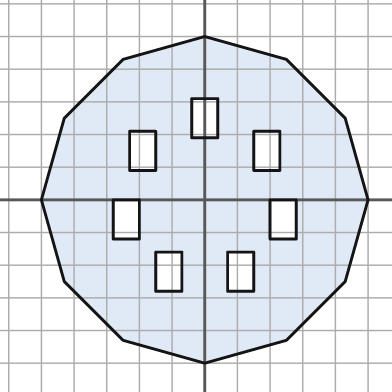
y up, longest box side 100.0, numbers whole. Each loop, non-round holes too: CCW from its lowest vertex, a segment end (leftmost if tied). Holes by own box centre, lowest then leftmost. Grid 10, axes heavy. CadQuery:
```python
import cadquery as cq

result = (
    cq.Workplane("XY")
    .moveTo(0.0, -50.0)
    .lineTo(25.0, -43.0)
    .lineTo(43.0, -25.0)
    .lineTo(50.0, 0.0)
    .lineTo(43.0, 25.0)
    .lineTo(25.0, 43.0)
    .lineTo(0.0, 50.0)
    .lineTo(-25.0, 43.0)
    .lineTo(-43.0, 25.0)
    .lineTo(-50.0, 0.0)
    .lineTo(-43.0, -25.0)
    .lineTo(-25.0, -43.0)
    .close()
    .moveTo(-15.0, -28.0)
    .lineTo(-7.0, -28.0)
    .lineTo(-7.0, -16.0)
    .lineTo(-15.0, -16.0)
    .close()
    .moveTo(7.0, -28.0)
    .lineTo(15.0, -28.0)
    .lineTo(15.0, -16.0)
    .lineTo(7.0, -16.0)
    .close()
    .moveTo(-28.0, -12.0)
    .lineTo(-20.0, -12.0)
    .lineTo(-20.0, 0.0)
    .lineTo(-28.0, 0.0)
    .close()
    .moveTo(20.0, -12.0)
    .lineTo(28.0, -12.0)
    .lineTo(28.0, 0.0)
    .lineTo(20.0, 0.0)
    .close()
    .moveTo(-23.0, 9.0)
    .lineTo(-15.0, 9.0)
    .lineTo(-15.0, 21.0)
    .lineTo(-23.0, 21.0)
    .close()
    .moveTo(15.0, 9.0)
    .lineTo(23.0, 9.0)
    .lineTo(23.0, 21.0)
    .lineTo(15.0, 21.0)
    .close()
    .moveTo(-4.0, 19.0)
    .lineTo(4.0, 19.0)
    .lineTo(4.0, 31.0)
    .lineTo(-4.0, 31.0)
    .close()
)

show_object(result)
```